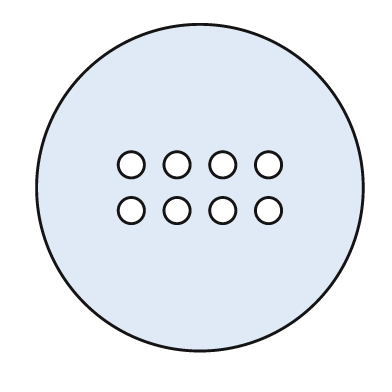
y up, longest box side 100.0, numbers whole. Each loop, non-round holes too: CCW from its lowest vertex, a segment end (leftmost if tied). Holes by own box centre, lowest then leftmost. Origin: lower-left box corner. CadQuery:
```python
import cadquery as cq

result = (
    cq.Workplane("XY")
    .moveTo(50.0, 50.0)
    .circle(50.0)
    .moveTo(29.0, 43.0)
    .circle(4.0)
    .moveTo(43.0, 43.0)
    .circle(4.0)
    .moveTo(57.0, 43.0)
    .circle(4.0)
    .moveTo(71.0, 43.0)
    .circle(4.0)
    .moveTo(29.0, 57.0)
    .circle(4.0)
    .moveTo(43.0, 57.0)
    .circle(4.0)
    .moveTo(57.0, 57.0)
    .circle(4.0)
    .moveTo(71.0, 57.0)
    .circle(4.0)
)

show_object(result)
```